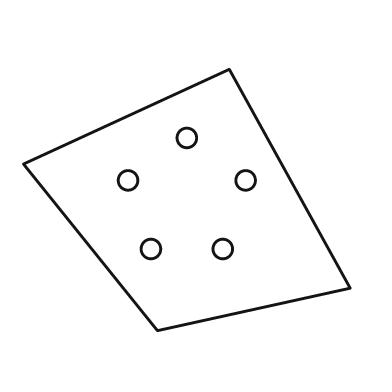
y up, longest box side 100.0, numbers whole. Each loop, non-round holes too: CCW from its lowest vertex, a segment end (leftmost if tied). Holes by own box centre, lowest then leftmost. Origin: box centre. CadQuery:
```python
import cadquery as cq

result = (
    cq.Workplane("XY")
    .moveTo(-9.0, -40.0)
    .lineTo(50.0, -27.0)
    .lineTo(13.0, 40.0)
    .lineTo(-50.0, 11.0)
    .close()
    .moveTo(-11.0, -15.0)
    .circle(3.0)
    .moveTo(11.0, -15.0)
    .circle(3.0)
    .moveTo(-18.0, 6.0)
    .circle(3.0)
    .moveTo(18.0, 6.0)
    .circle(3.0)
    .moveTo(0.0, 19.0)
    .circle(3.0)
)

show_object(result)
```